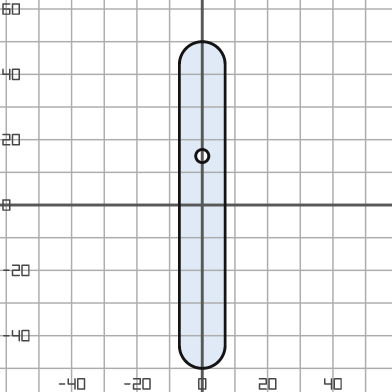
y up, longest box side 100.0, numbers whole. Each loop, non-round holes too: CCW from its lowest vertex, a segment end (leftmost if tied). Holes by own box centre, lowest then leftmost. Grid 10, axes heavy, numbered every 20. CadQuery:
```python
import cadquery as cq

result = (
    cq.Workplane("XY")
    .moveTo(-7.0, -43.0)
    .threePointArc((0.0, -50.0), (7.0, -43.0))
    .lineTo(7.0, 43.0)
    .threePointArc((0.0, 50.0), (-7.0, 43.0))
    .close()
    .moveTo(0.0, 15.0)
    .circle(2.0)
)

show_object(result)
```